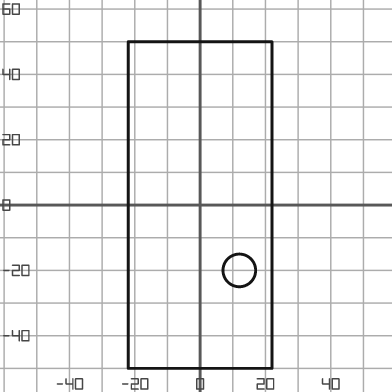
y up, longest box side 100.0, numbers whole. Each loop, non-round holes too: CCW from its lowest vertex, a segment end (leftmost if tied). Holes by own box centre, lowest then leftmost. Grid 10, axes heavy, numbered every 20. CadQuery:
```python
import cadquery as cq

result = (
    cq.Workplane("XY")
    .moveTo(-22.0, -50.0)
    .lineTo(22.0, -50.0)
    .lineTo(22.0, 50.0)
    .lineTo(-22.0, 50.0)
    .close()
    .moveTo(12.0, -20.0)
    .circle(5.0)
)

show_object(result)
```